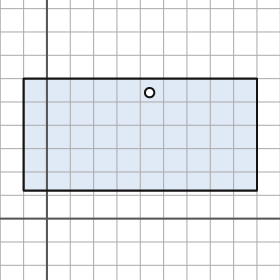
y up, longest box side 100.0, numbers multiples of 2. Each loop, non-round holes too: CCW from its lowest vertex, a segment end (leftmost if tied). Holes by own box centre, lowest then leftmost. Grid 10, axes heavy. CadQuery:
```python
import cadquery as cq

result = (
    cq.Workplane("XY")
    .moveTo(-10.0, 12.0)
    .lineTo(90.0, 12.0)
    .lineTo(90.0, 60.0)
    .lineTo(-10.0, 60.0)
    .close()
    .moveTo(44.0, 54.0)
    .circle(2.0)
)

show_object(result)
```